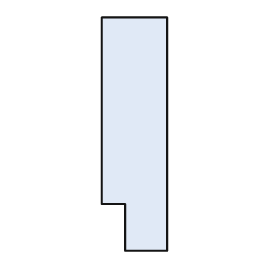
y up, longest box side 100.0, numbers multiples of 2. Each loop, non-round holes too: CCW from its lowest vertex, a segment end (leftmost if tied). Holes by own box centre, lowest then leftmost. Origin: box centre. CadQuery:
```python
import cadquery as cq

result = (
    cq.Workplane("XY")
    .moveTo(-4.0, -50.0)
    .lineTo(14.0, -50.0)
    .lineTo(14.0, 50.0)
    .lineTo(-14.0, 50.0)
    .lineTo(-14.0, -30.0)
    .lineTo(-4.0, -30.0)
    .close()
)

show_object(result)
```